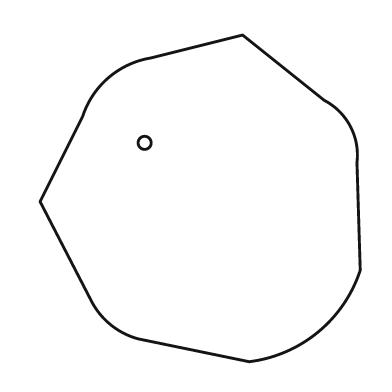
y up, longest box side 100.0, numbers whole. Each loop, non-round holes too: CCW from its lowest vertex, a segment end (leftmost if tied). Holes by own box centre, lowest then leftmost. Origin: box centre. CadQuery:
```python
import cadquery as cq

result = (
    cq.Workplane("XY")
    .moveTo(15.0, -50.0)
    .threePointArc((36.0, -41.0), (49.0, -22.0))
    .lineTo(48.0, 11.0)
    .threePointArc((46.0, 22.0), (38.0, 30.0))
    .lineTo(13.0, 50.0)
    .lineTo(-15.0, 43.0)
    .threePointArc((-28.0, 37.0), (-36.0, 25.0))
    .lineTo(-49.0, -1.0)
    .lineTo(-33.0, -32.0)
    .threePointArc((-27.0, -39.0), (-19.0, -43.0))
    .close()
    .moveTo(-17.0, 17.0)
    .circle(2.0)
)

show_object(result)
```